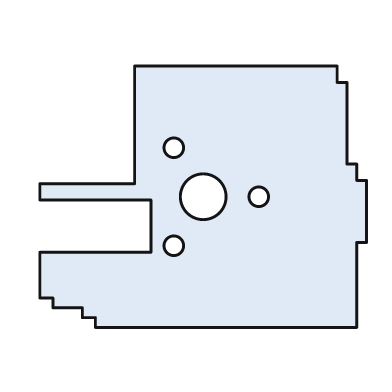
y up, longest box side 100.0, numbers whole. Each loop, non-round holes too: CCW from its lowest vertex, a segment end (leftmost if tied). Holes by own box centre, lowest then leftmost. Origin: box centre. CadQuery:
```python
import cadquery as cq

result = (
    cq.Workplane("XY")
    .moveTo(-33.0, -40.0)
    .lineTo(47.0, -40.0)
    .lineTo(47.0, -14.0)
    .lineTo(50.0, -14.0)
    .lineTo(50.0, 5.0)
    .lineTo(47.0, 5.0)
    .lineTo(47.0, 10.0)
    .lineTo(44.0, 10.0)
    .lineTo(44.0, 35.0)
    .lineTo(41.0, 35.0)
    .lineTo(41.0, 40.0)
    .lineTo(-21.0, 40.0)
    .lineTo(-21.0, 4.0)
    .lineTo(-50.0, 4.0)
    .lineTo(-50.0, -1.0)
    .lineTo(-16.0, -1.0)
    .lineTo(-16.0, -17.0)
    .lineTo(-50.0, -17.0)
    .lineTo(-50.0, -31.0)
    .lineTo(-46.0, -31.0)
    .lineTo(-46.0, -34.0)
    .lineTo(-37.0, -34.0)
    .lineTo(-37.0, -37.0)
    .lineTo(-33.0, -37.0)
    .close()
    .moveTo(-9.0, -15.0)
    .circle(3.0)
    .moveTo(0.0, 0.0)
    .circle(7.0)
    .moveTo(17.0, 0.0)
    .circle(3.0)
    .moveTo(-9.0, 15.0)
    .circle(3.0)
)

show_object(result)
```